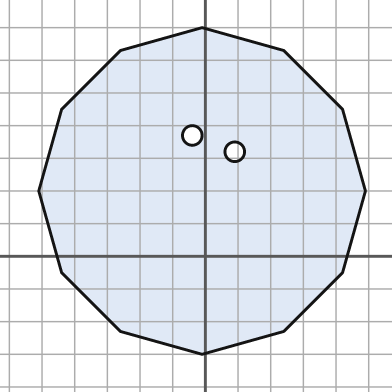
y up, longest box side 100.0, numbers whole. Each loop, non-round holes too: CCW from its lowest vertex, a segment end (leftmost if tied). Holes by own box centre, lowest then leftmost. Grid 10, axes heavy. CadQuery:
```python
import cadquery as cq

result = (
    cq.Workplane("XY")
    .moveTo(-1.0, -30.0)
    .lineTo(24.0, -23.0)
    .lineTo(42.0, -5.0)
    .lineTo(49.0, 20.0)
    .lineTo(42.0, 45.0)
    .lineTo(24.0, 63.0)
    .lineTo(-1.0, 70.0)
    .lineTo(-26.0, 63.0)
    .lineTo(-44.0, 45.0)
    .lineTo(-51.0, 20.0)
    .lineTo(-44.0, -5.0)
    .lineTo(-26.0, -23.0)
    .close()
    .moveTo(9.0, 32.0)
    .circle(3.0)
    .moveTo(-4.0, 37.0)
    .circle(3.0)
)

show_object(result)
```